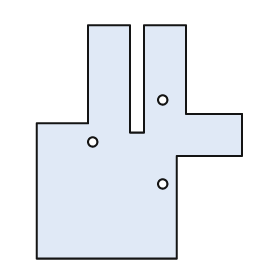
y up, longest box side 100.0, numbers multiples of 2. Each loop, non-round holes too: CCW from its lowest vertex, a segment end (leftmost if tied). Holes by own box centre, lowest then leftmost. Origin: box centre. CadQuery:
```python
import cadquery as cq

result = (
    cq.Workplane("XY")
    .moveTo(-44.0, -50.0)
    .lineTo(16.0, -50.0)
    .lineTo(16.0, -6.0)
    .lineTo(44.0, -6.0)
    .lineTo(44.0, 12.0)
    .lineTo(20.0, 12.0)
    .lineTo(20.0, 50.0)
    .lineTo(2.0, 50.0)
    .lineTo(2.0, 4.0)
    .lineTo(-4.0, 4.0)
    .lineTo(-4.0, 50.0)
    .lineTo(-22.0, 50.0)
    .lineTo(-22.0, 8.0)
    .lineTo(-44.0, 8.0)
    .close()
    .moveTo(10.0, -18.0)
    .circle(2.0)
    .moveTo(-20.0, 0.0)
    .circle(2.0)
    .moveTo(10.0, 18.0)
    .circle(2.0)
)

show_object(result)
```